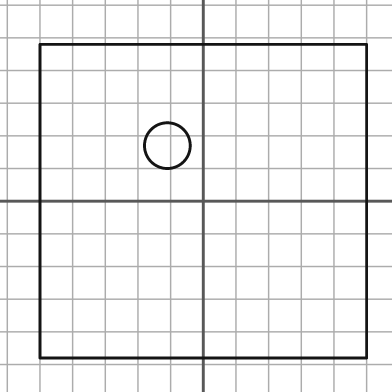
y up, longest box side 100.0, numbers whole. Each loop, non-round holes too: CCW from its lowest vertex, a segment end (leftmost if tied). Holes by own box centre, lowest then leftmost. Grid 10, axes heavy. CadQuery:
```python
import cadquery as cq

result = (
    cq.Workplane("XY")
    .moveTo(-50.0, -48.0)
    .lineTo(50.0, -48.0)
    .lineTo(50.0, 48.0)
    .lineTo(-50.0, 48.0)
    .close()
    .moveTo(-11.0, 17.0)
    .circle(7.0)
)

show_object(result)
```